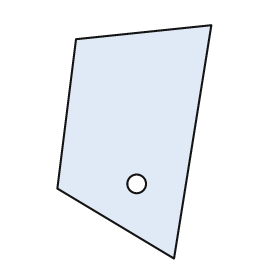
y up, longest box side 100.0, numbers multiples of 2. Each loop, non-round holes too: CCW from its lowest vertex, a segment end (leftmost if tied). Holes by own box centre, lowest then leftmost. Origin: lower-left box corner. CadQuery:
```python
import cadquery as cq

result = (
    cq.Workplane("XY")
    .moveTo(50.0, 0.0)
    .lineTo(66.0, 100.0)
    .lineTo(8.0, 94.0)
    .lineTo(0.0, 30.0)
    .close()
    .moveTo(34.0, 32.0)
    .circle(4.0)
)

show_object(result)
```